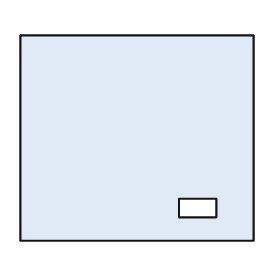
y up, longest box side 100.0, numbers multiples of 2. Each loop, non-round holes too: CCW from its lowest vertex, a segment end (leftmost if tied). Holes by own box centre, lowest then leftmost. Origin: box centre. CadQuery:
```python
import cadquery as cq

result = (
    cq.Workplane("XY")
    .moveTo(-50.0, -44.0)
    .lineTo(50.0, -44.0)
    .lineTo(50.0, 44.0)
    .lineTo(-50.0, 44.0)
    .close()
    .moveTo(18.0, -34.0)
    .lineTo(34.0, -34.0)
    .lineTo(34.0, -26.0)
    .lineTo(18.0, -26.0)
    .close()
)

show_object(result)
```